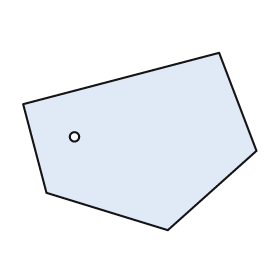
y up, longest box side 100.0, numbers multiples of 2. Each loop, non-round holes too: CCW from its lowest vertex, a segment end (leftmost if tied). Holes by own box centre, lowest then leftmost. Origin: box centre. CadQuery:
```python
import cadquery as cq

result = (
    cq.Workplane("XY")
    .moveTo(12.0, -38.0)
    .lineTo(50.0, -4.0)
    .lineTo(34.0, 38.0)
    .lineTo(-50.0, 16.0)
    .lineTo(-40.0, -22.0)
    .close()
    .moveTo(-28.0, 2.0)
    .circle(2.0)
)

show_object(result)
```